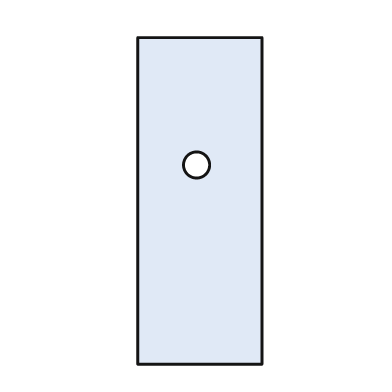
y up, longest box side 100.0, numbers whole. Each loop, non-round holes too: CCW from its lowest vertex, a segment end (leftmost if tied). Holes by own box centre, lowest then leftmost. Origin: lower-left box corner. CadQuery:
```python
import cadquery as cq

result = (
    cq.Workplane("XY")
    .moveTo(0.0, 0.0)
    .lineTo(38.0, 0.0)
    .lineTo(38.0, 100.0)
    .lineTo(0.0, 100.0)
    .close()
    .moveTo(18.0, 61.0)
    .circle(4.0)
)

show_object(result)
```